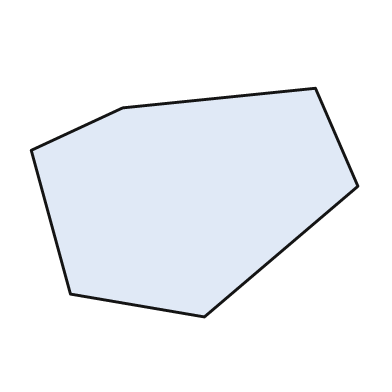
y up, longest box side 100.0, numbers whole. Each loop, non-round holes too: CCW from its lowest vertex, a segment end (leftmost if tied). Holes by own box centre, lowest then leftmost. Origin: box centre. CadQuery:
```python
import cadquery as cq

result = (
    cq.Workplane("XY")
    .moveTo(3.0, -35.0)
    .lineTo(50.0, 5.0)
    .lineTo(37.0, 35.0)
    .lineTo(-22.0, 29.0)
    .lineTo(-50.0, 16.0)
    .lineTo(-38.0, -28.0)
    .close()
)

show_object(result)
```